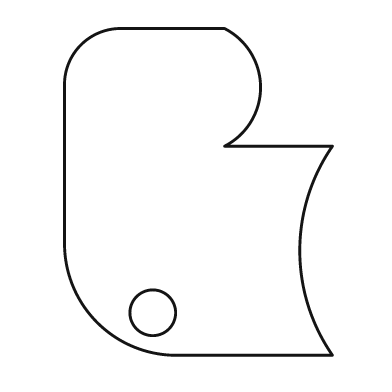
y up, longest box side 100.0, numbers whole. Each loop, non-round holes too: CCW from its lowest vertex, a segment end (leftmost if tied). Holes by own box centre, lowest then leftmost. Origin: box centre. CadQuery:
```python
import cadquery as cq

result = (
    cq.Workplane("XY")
    .moveTo(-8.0, -50.0)
    .lineTo(41.0, -50.0)
    .threePointArc((31.0, -18.0), (41.0, 14.0))
    .lineTo(8.0, 14.0)
    .threePointArc((19.0, 32.0), (8.0, 50.0))
    .lineTo(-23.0, 50.0)
    .threePointArc((-36.0, 45.0), (-41.0, 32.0))
    .lineTo(-41.0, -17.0)
    .threePointArc((-31.0, -40.0), (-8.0, -50.0))
    .close()
    .moveTo(-14.0, -37.0)
    .circle(7.0)
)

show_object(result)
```